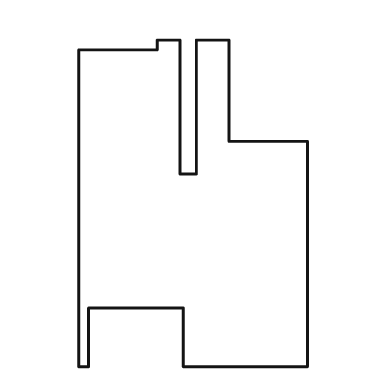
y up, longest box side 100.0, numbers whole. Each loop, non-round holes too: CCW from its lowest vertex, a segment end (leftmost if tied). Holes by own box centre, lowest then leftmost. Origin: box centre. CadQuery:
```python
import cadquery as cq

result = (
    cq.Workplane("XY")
    .moveTo(-35.0, -50.0)
    .lineTo(-32.0, -50.0)
    .lineTo(-32.0, -32.0)
    .lineTo(-3.0, -32.0)
    .lineTo(-3.0, -50.0)
    .lineTo(35.0, -50.0)
    .lineTo(35.0, 19.0)
    .lineTo(11.0, 19.0)
    .lineTo(11.0, 50.0)
    .lineTo(1.0, 50.0)
    .lineTo(1.0, 9.0)
    .lineTo(-4.0, 9.0)
    .lineTo(-4.0, 50.0)
    .lineTo(-11.0, 50.0)
    .lineTo(-11.0, 47.0)
    .lineTo(-35.0, 47.0)
    .close()
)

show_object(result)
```